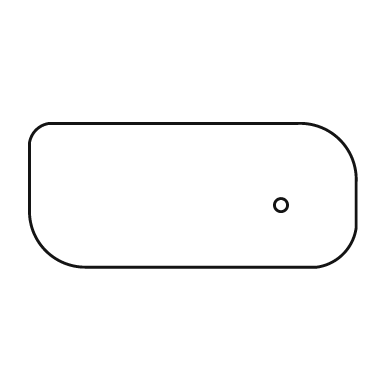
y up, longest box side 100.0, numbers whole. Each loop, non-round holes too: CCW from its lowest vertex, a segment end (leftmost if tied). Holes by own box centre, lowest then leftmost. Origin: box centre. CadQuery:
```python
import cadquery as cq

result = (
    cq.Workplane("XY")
    .moveTo(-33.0, -22.0)
    .lineTo(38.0, -22.0)
    .threePointArc((46.0, -18.0), (50.0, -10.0))
    .lineTo(50.0, 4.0)
    .threePointArc((45.0, 17.0), (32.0, 22.0))
    .lineTo(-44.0, 22.0)
    .threePointArc((-48.0, 20.0), (-50.0, 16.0))
    .lineTo(-50.0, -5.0)
    .threePointArc((-45.0, -17.0), (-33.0, -22.0))
    .close()
    .moveTo(27.0, -3.0)
    .circle(2.0)
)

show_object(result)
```